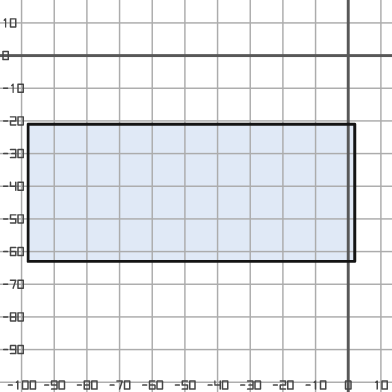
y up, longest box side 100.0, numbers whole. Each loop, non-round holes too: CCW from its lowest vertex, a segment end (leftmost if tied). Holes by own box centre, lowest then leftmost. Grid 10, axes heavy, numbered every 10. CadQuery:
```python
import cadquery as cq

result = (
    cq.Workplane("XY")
    .moveTo(-98.0, -63.0)
    .lineTo(2.0, -63.0)
    .lineTo(2.0, -21.0)
    .lineTo(-98.0, -21.0)
    .close()
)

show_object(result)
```